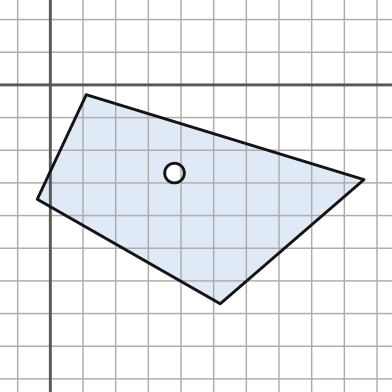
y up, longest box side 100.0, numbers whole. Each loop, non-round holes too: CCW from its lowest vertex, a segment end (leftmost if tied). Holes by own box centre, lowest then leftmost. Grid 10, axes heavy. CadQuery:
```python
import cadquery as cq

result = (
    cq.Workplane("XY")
    .moveTo(52.0, -67.0)
    .lineTo(96.0, -29.0)
    .lineTo(11.0, -3.0)
    .lineTo(-4.0, -35.0)
    .close()
    .moveTo(38.0, -27.0)
    .circle(3.0)
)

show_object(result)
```